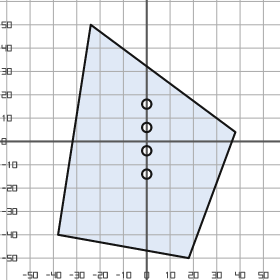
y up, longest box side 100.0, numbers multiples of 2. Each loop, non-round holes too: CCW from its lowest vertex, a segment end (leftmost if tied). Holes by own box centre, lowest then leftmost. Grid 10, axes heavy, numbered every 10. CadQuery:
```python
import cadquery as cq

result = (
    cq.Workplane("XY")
    .moveTo(18.0, -50.0)
    .lineTo(38.0, 4.0)
    .lineTo(-24.0, 50.0)
    .lineTo(-38.0, -40.0)
    .close()
    .moveTo(0.0, -14.0)
    .circle(2.0)
    .moveTo(0.0, -4.0)
    .circle(2.0)
    .moveTo(0.0, 6.0)
    .circle(2.0)
    .moveTo(0.0, 16.0)
    .circle(2.0)
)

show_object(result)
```